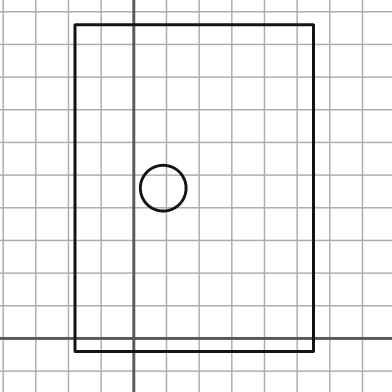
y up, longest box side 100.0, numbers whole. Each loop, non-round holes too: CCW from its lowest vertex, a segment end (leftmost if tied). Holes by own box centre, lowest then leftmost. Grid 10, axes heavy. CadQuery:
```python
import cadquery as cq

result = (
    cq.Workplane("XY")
    .moveTo(-18.0, -4.0)
    .lineTo(55.0, -4.0)
    .lineTo(55.0, 96.0)
    .lineTo(-18.0, 96.0)
    .close()
    .moveTo(9.0, 46.0)
    .circle(7.0)
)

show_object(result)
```